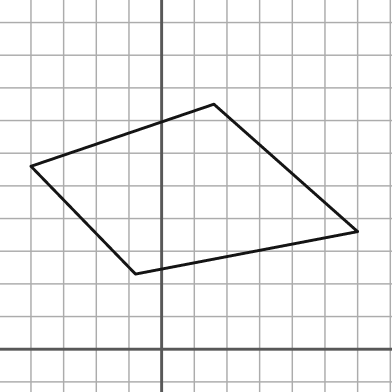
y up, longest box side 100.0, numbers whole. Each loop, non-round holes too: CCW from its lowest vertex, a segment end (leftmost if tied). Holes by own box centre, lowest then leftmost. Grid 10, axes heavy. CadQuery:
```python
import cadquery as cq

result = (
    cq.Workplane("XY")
    .moveTo(-8.0, 23.0)
    .lineTo(60.0, 36.0)
    .lineTo(16.0, 75.0)
    .lineTo(-40.0, 56.0)
    .close()
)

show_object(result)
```